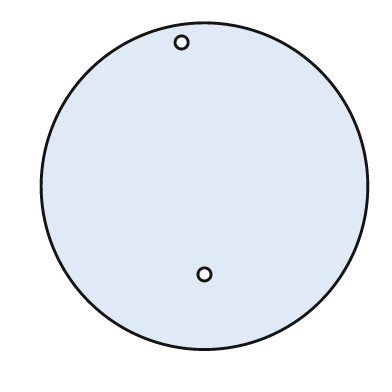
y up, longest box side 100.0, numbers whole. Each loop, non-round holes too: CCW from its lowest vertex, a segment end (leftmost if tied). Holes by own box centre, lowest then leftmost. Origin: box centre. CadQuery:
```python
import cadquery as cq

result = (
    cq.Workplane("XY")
    .moveTo(0.0, 0.0)
    .circle(50.0)
    .moveTo(0.0, -27.0)
    .circle(2.0)
    .moveTo(-7.0, 44.0)
    .circle(2.0)
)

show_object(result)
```